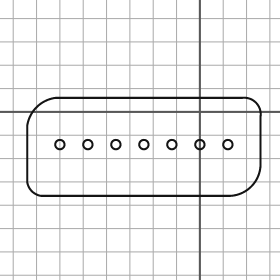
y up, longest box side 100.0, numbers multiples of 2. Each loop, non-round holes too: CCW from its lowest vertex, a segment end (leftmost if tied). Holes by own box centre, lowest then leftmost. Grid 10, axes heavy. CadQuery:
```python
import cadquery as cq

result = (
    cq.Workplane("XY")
    .moveTo(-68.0, -36.0)
    .lineTo(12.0, -36.0)
    .threePointArc((22.0, -32.0), (26.0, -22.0))
    .lineTo(26.0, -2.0)
    .threePointArc((24.0, 4.0), (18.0, 6.0))
    .lineTo(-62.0, 6.0)
    .threePointArc((-70.0, 2.0), (-74.0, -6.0))
    .lineTo(-74.0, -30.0)
    .threePointArc((-72.0, -34.0), (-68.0, -36.0))
    .close()
    .moveTo(-60.0, -14.0)
    .circle(2.0)
    .moveTo(-48.0, -14.0)
    .circle(2.0)
    .moveTo(-36.0, -14.0)
    .circle(2.0)
    .moveTo(-24.0, -14.0)
    .circle(2.0)
    .moveTo(-12.0, -14.0)
    .circle(2.0)
    .moveTo(0.0, -14.0)
    .circle(2.0)
    .moveTo(12.0, -14.0)
    .circle(2.0)
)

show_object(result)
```